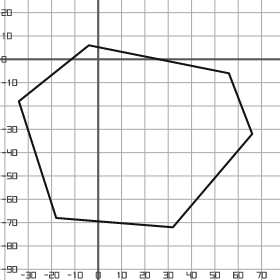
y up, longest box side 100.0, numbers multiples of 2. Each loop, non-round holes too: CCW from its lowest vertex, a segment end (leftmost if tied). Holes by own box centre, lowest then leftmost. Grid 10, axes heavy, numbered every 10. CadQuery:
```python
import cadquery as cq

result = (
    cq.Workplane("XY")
    .moveTo(32.0, -72.0)
    .lineTo(66.0, -32.0)
    .lineTo(56.0, -6.0)
    .lineTo(-4.0, 6.0)
    .lineTo(-34.0, -18.0)
    .lineTo(-18.0, -68.0)
    .close()
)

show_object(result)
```